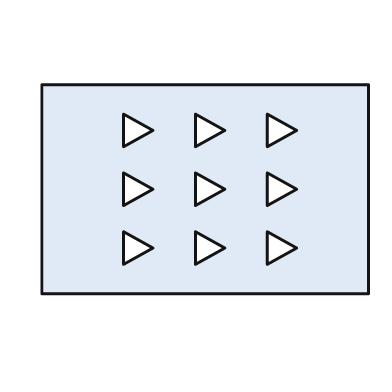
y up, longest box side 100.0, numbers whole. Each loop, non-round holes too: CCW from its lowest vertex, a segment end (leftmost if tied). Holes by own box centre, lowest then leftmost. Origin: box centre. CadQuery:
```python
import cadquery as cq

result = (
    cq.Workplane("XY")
    .moveTo(-50.0, -32.0)
    .lineTo(50.0, -32.0)
    .lineTo(50.0, 32.0)
    .lineTo(-50.0, 32.0)
    .close()
    .moveTo(-25.0, -23.0)
    .lineTo(-16.0, -18.0)
    .lineTo(-25.0, -13.0)
    .close()
    .moveTo(-3.0, -23.0)
    .lineTo(6.0, -18.0)
    .lineTo(-3.0, -13.0)
    .close()
    .moveTo(19.0, -23.0)
    .lineTo(28.0, -18.0)
    .lineTo(19.0, -13.0)
    .close()
    .moveTo(-25.0, -5.0)
    .lineTo(-16.0, 0.0)
    .lineTo(-25.0, 5.0)
    .close()
    .moveTo(-3.0, -5.0)
    .lineTo(6.0, 0.0)
    .lineTo(-3.0, 5.0)
    .close()
    .moveTo(19.0, -5.0)
    .lineTo(28.0, 0.0)
    .lineTo(19.0, 5.0)
    .close()
    .moveTo(-25.0, 13.0)
    .lineTo(-16.0, 18.0)
    .lineTo(-25.0, 23.0)
    .close()
    .moveTo(-3.0, 13.0)
    .lineTo(6.0, 18.0)
    .lineTo(-3.0, 23.0)
    .close()
    .moveTo(19.0, 13.0)
    .lineTo(28.0, 18.0)
    .lineTo(19.0, 23.0)
    .close()
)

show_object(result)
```